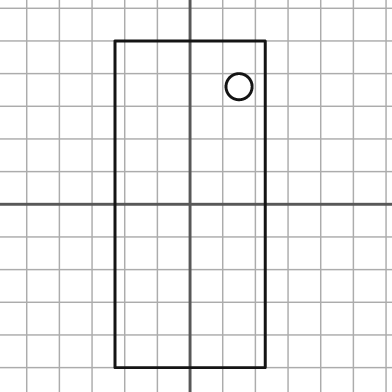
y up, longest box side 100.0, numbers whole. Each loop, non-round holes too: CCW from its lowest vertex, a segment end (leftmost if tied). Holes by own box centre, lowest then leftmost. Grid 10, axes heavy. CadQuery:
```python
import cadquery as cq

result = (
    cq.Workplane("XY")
    .moveTo(-23.0, -50.0)
    .lineTo(23.0, -50.0)
    .lineTo(23.0, 50.0)
    .lineTo(-23.0, 50.0)
    .close()
    .moveTo(15.0, 36.0)
    .circle(4.0)
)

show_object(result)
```